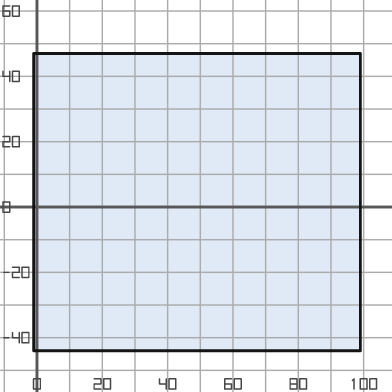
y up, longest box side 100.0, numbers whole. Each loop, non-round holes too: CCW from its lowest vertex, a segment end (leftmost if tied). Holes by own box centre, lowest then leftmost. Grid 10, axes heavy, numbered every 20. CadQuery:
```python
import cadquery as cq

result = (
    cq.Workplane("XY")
    .moveTo(-1.0, -44.0)
    .lineTo(99.0, -44.0)
    .lineTo(99.0, 47.0)
    .lineTo(-1.0, 47.0)
    .close()
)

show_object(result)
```